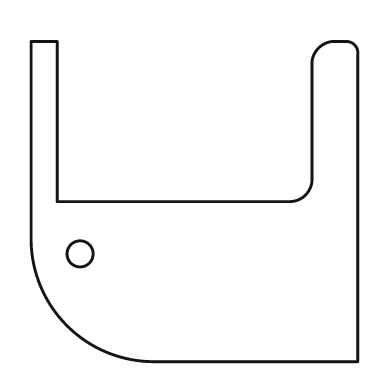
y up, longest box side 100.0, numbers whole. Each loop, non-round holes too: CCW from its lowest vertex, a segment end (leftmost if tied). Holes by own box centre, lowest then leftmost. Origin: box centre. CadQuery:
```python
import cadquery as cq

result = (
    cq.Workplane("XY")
    .moveTo(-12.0, -49.0)
    .lineTo(50.0, -49.0)
    .lineTo(50.0, 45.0)
    .threePointArc((49.0, 48.0), (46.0, 49.0))
    .lineTo(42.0, 49.0)
    .threePointArc((38.0, 47.0), (36.0, 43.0))
    .lineTo(36.0, 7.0)
    .threePointArc((34.0, 2.0), (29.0, 0.0))
    .lineTo(-42.0, 0.0)
    .lineTo(-42.0, 49.0)
    .lineTo(-50.0, 49.0)
    .lineTo(-50.0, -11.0)
    .threePointArc((-39.0, -38.0), (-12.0, -49.0))
    .close()
    .moveTo(-35.0, -16.0)
    .circle(4.0)
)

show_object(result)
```